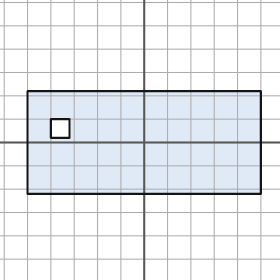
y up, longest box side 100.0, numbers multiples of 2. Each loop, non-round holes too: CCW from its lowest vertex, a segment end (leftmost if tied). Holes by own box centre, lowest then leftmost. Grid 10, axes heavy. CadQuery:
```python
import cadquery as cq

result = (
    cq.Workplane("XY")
    .moveTo(-50.0, -22.0)
    .lineTo(50.0, -22.0)
    .lineTo(50.0, 22.0)
    .lineTo(-50.0, 22.0)
    .close()
    .moveTo(-40.0, 2.0)
    .lineTo(-32.0, 2.0)
    .lineTo(-32.0, 10.0)
    .lineTo(-40.0, 10.0)
    .close()
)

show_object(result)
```